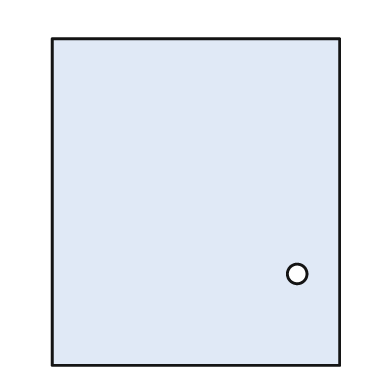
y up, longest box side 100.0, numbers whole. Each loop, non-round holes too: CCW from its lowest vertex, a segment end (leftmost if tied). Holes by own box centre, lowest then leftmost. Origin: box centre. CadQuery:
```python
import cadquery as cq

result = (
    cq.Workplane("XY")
    .moveTo(-44.0, -50.0)
    .lineTo(44.0, -50.0)
    .lineTo(44.0, 50.0)
    .lineTo(-44.0, 50.0)
    .close()
    .moveTo(31.0, -22.0)
    .circle(3.0)
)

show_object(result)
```